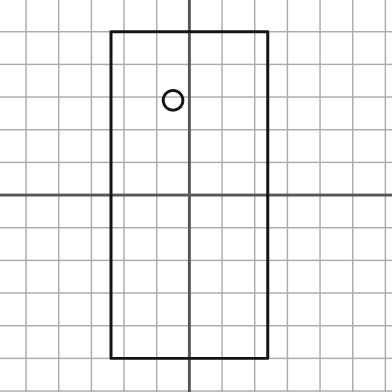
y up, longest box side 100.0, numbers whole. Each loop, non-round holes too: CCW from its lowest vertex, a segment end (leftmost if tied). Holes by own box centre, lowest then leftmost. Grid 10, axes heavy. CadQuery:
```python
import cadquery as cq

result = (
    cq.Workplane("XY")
    .moveTo(-24.0, -50.0)
    .lineTo(24.0, -50.0)
    .lineTo(24.0, 50.0)
    .lineTo(-24.0, 50.0)
    .close()
    .moveTo(-5.0, 29.0)
    .circle(3.0)
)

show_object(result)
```